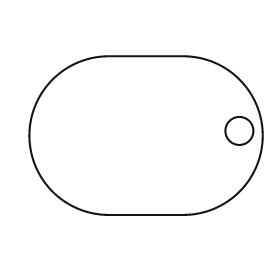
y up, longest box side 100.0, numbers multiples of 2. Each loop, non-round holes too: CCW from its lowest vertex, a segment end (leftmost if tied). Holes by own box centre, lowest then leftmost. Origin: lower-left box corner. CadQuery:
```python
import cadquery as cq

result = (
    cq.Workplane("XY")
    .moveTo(34.0, 0.0)
    .lineTo(66.0, 0.0)
    .threePointArc((100.0, 34.0), (66.0, 68.0))
    .lineTo(34.0, 68.0)
    .threePointArc((0.0, 34.0), (34.0, 0.0))
    .close()
    .moveTo(90.0, 36.0)
    .circle(6.0)
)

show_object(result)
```